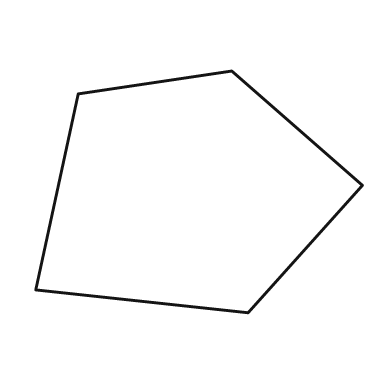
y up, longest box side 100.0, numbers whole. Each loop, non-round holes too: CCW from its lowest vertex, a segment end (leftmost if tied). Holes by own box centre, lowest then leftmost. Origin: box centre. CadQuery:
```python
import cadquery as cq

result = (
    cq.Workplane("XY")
    .moveTo(15.0, -37.0)
    .lineTo(50.0, 2.0)
    .lineTo(10.0, 37.0)
    .lineTo(-37.0, 30.0)
    .lineTo(-50.0, -30.0)
    .close()
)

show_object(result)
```